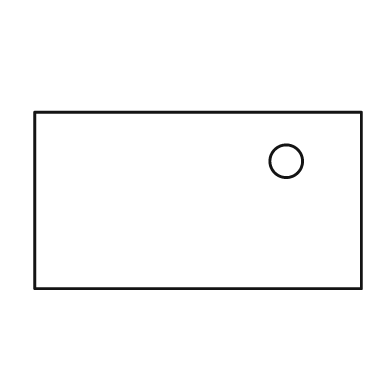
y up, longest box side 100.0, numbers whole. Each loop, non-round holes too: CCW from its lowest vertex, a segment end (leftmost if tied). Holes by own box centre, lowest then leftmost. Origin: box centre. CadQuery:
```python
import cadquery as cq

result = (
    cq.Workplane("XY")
    .moveTo(-50.0, -27.0)
    .lineTo(50.0, -27.0)
    .lineTo(50.0, 27.0)
    .lineTo(-50.0, 27.0)
    .close()
    .moveTo(27.0, 12.0)
    .circle(5.0)
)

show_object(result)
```